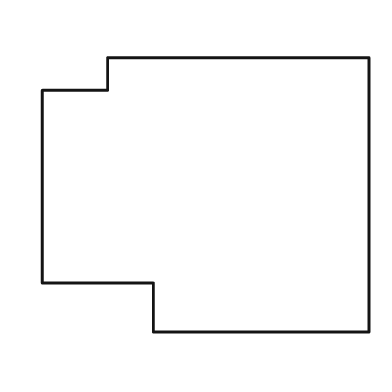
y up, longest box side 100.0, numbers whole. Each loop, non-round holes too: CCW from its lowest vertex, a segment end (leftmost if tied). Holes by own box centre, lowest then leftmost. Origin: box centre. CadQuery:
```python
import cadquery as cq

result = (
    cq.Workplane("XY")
    .moveTo(-16.0, -42.0)
    .lineTo(50.0, -42.0)
    .lineTo(50.0, 42.0)
    .lineTo(-30.0, 42.0)
    .lineTo(-30.0, 32.0)
    .lineTo(-50.0, 32.0)
    .lineTo(-50.0, -27.0)
    .lineTo(-16.0, -27.0)
    .close()
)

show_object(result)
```